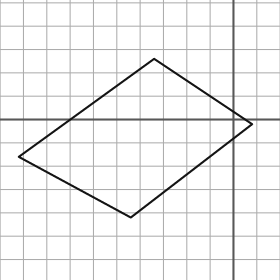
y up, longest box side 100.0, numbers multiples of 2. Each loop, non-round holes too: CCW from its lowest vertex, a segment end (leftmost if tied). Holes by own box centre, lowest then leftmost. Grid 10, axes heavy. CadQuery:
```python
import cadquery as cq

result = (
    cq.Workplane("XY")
    .moveTo(-44.0, -42.0)
    .lineTo(8.0, -2.0)
    .lineTo(-34.0, 26.0)
    .lineTo(-92.0, -16.0)
    .close()
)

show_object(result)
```